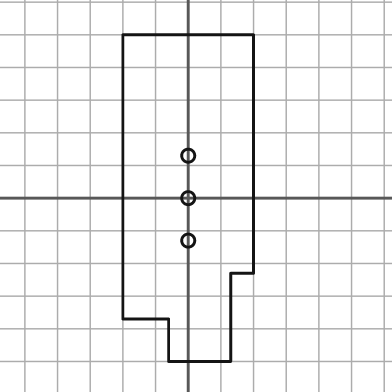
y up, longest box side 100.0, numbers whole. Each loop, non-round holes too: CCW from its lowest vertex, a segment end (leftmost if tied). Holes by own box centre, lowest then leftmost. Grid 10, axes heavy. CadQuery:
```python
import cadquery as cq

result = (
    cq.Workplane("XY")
    .moveTo(-6.0, -50.0)
    .lineTo(13.0, -50.0)
    .lineTo(13.0, -23.0)
    .lineTo(20.0, -23.0)
    .lineTo(20.0, 50.0)
    .lineTo(-20.0, 50.0)
    .lineTo(-20.0, -37.0)
    .lineTo(-6.0, -37.0)
    .close()
    .moveTo(0.0, -13.0)
    .circle(2.0)
    .moveTo(0.0, 0.0)
    .circle(2.0)
    .moveTo(0.0, 13.0)
    .circle(2.0)
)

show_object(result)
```